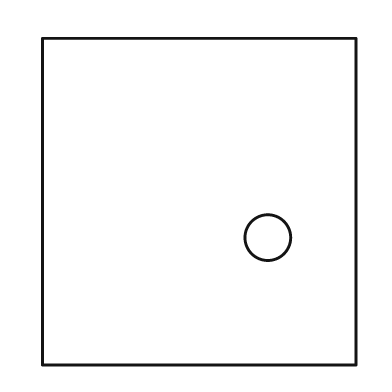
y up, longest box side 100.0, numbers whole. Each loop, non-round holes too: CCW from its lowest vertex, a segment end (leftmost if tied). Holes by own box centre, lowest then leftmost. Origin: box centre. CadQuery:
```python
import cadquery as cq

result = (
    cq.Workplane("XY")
    .moveTo(-48.0, -50.0)
    .lineTo(48.0, -50.0)
    .lineTo(48.0, 50.0)
    .lineTo(-48.0, 50.0)
    .close()
    .moveTo(21.0, -11.0)
    .circle(7.0)
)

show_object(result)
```